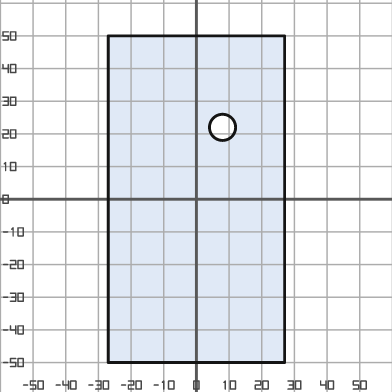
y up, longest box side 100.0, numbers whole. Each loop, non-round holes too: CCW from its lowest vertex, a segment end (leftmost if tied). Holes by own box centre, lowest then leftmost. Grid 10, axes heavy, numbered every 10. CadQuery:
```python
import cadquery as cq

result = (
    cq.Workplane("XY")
    .moveTo(-27.0, -50.0)
    .lineTo(27.0, -50.0)
    .lineTo(27.0, 50.0)
    .lineTo(-27.0, 50.0)
    .close()
    .moveTo(8.0, 22.0)
    .circle(4.0)
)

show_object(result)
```